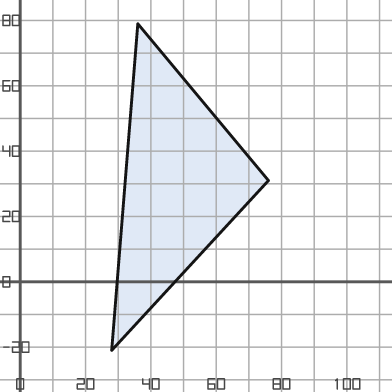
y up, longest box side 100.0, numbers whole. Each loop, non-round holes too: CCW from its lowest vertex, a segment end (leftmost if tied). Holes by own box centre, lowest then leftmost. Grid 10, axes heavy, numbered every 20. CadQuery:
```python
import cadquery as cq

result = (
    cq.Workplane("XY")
    .moveTo(28.0, -21.0)
    .lineTo(76.0, 31.0)
    .lineTo(36.0, 79.0)
    .close()
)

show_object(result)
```